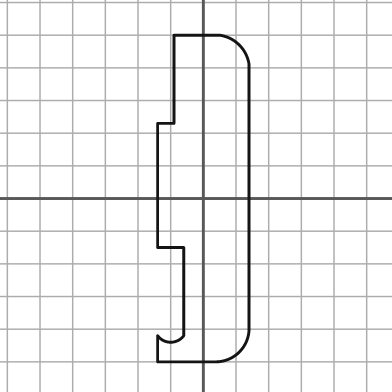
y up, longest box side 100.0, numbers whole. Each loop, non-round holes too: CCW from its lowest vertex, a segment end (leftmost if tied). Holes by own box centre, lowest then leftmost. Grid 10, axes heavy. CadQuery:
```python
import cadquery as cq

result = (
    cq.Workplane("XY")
    .moveTo(-14.0, -50.0)
    .lineTo(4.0, -50.0)
    .threePointArc((11.0, -47.0), (14.0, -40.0))
    .lineTo(14.0, 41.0)
    .threePointArc((11.0, 47.0), (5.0, 50.0))
    .lineTo(-9.0, 50.0)
    .lineTo(-9.0, 23.0)
    .lineTo(-14.0, 23.0)
    .lineTo(-14.0, -15.0)
    .lineTo(-6.0, -15.0)
    .lineTo(-6.0, -42.0)
    .threePointArc((-10.0, -44.0), (-14.0, -42.0))
    .close()
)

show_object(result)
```